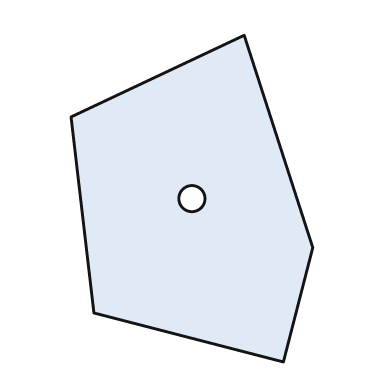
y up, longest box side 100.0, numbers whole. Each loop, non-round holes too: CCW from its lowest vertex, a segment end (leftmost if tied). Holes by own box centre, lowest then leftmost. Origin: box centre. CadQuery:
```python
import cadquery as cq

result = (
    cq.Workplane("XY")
    .moveTo(28.0, -50.0)
    .lineTo(37.0, -15.0)
    .lineTo(16.0, 50.0)
    .lineTo(-37.0, 25.0)
    .lineTo(-30.0, -35.0)
    .close()
    .moveTo(0.0, 0.0)
    .circle(4.0)
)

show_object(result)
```